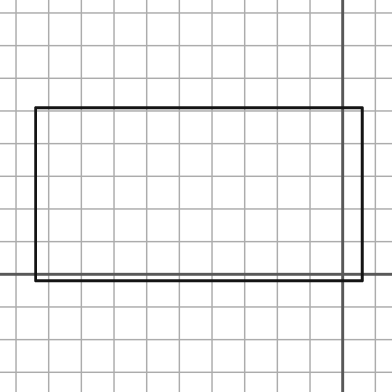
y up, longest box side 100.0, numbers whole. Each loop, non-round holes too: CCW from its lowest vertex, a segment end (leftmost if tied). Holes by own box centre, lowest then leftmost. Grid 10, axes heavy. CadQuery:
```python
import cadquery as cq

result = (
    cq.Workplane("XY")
    .moveTo(-94.0, -2.0)
    .lineTo(6.0, -2.0)
    .lineTo(6.0, 51.0)
    .lineTo(-94.0, 51.0)
    .close()
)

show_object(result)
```